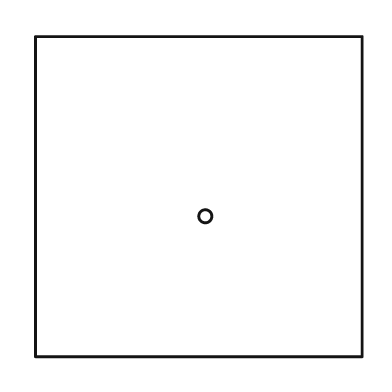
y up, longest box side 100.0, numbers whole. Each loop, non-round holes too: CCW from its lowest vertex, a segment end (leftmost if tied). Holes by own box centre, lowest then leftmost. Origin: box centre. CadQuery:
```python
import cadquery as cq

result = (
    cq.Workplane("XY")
    .moveTo(-50.0, -49.0)
    .lineTo(50.0, -49.0)
    .lineTo(50.0, 49.0)
    .lineTo(-50.0, 49.0)
    .close()
    .moveTo(2.0, -6.0)
    .circle(2.0)
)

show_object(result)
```